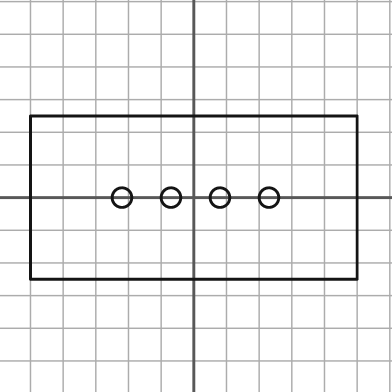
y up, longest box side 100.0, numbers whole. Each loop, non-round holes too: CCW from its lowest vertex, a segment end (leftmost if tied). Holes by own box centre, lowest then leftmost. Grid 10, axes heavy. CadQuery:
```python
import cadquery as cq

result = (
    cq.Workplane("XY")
    .moveTo(-50.0, -25.0)
    .lineTo(50.0, -25.0)
    .lineTo(50.0, 25.0)
    .lineTo(-50.0, 25.0)
    .close()
    .moveTo(-22.0, 0.0)
    .circle(3.0)
    .moveTo(-7.0, 0.0)
    .circle(3.0)
    .moveTo(8.0, 0.0)
    .circle(3.0)
    .moveTo(23.0, 0.0)
    .circle(3.0)
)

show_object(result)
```